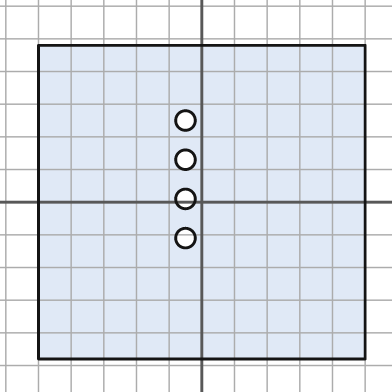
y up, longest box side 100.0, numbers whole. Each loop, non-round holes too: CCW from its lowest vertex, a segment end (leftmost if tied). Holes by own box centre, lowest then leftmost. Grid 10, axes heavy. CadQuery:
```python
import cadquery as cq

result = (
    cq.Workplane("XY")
    .moveTo(-50.0, -48.0)
    .lineTo(50.0, -48.0)
    .lineTo(50.0, 48.0)
    .lineTo(-50.0, 48.0)
    .close()
    .moveTo(-5.0, -11.0)
    .circle(3.0)
    .moveTo(-5.0, 1.0)
    .circle(3.0)
    .moveTo(-5.0, 13.0)
    .circle(3.0)
    .moveTo(-5.0, 25.0)
    .circle(3.0)
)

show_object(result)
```